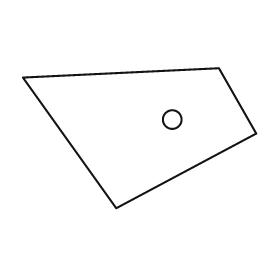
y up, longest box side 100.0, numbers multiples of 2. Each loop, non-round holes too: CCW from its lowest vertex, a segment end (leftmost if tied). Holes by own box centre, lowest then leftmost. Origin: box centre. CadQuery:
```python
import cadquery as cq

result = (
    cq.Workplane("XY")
    .moveTo(-10.0, -30.0)
    .lineTo(50.0, 2.0)
    .lineTo(34.0, 30.0)
    .lineTo(-50.0, 26.0)
    .close()
    .moveTo(14.0, 8.0)
    .circle(4.0)
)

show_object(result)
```